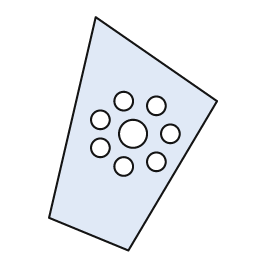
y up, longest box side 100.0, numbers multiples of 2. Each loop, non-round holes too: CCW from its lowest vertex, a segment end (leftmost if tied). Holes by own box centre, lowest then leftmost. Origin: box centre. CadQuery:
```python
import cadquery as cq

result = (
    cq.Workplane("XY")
    .moveTo(-2.0, -50.0)
    .lineTo(36.0, 14.0)
    .lineTo(-16.0, 50.0)
    .lineTo(-36.0, -36.0)
    .close()
    .moveTo(-4.0, -14.0)
    .circle(4.0)
    .moveTo(10.0, -12.0)
    .circle(4.0)
    .moveTo(-14.0, -6.0)
    .circle(4.0)
    .moveTo(0.0, 0.0)
    .circle(6.0)
    .moveTo(16.0, 0.0)
    .circle(4.0)
    .moveTo(-14.0, 6.0)
    .circle(4.0)
    .moveTo(10.0, 12.0)
    .circle(4.0)
    .moveTo(-4.0, 14.0)
    .circle(4.0)
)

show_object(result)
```